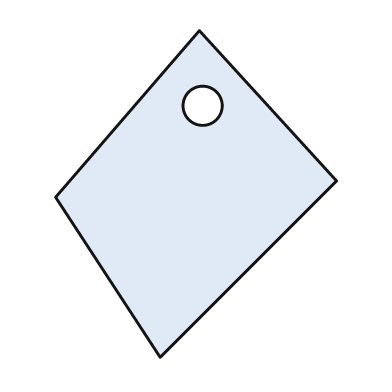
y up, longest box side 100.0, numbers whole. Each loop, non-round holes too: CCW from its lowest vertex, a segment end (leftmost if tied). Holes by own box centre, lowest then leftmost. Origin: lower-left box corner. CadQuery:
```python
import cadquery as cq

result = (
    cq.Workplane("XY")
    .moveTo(32.0, 0.0)
    .lineTo(86.0, 54.0)
    .lineTo(44.0, 100.0)
    .lineTo(0.0, 49.0)
    .close()
    .moveTo(45.0, 77.0)
    .circle(6.0)
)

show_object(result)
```